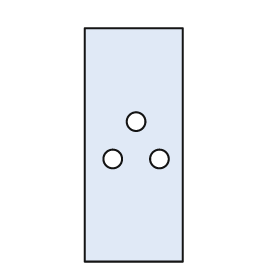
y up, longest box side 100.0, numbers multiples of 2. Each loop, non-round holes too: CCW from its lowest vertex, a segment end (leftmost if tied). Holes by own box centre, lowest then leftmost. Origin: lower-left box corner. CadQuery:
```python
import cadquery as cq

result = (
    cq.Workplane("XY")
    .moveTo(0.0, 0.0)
    .lineTo(42.0, 0.0)
    .lineTo(42.0, 100.0)
    .lineTo(0.0, 100.0)
    .close()
    .moveTo(12.0, 44.0)
    .circle(4.0)
    .moveTo(32.0, 44.0)
    .circle(4.0)
    .moveTo(22.0, 60.0)
    .circle(4.0)
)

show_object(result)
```